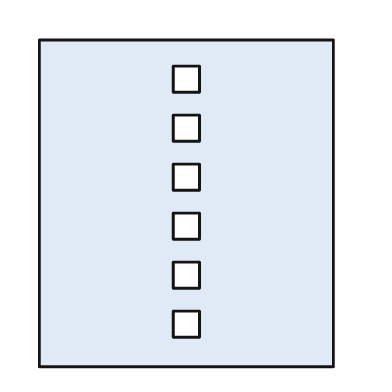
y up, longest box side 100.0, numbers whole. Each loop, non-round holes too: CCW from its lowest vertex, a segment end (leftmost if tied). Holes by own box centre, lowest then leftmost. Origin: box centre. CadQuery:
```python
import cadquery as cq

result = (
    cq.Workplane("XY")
    .moveTo(-45.0, -50.0)
    .lineTo(45.0, -50.0)
    .lineTo(45.0, 50.0)
    .lineTo(-45.0, 50.0)
    .close()
    .moveTo(-4.0, -41.0)
    .lineTo(4.0, -41.0)
    .lineTo(4.0, -33.0)
    .lineTo(-4.0, -33.0)
    .close()
    .moveTo(-4.0, -26.0)
    .lineTo(4.0, -26.0)
    .lineTo(4.0, -18.0)
    .lineTo(-4.0, -18.0)
    .close()
    .moveTo(-4.0, -11.0)
    .lineTo(4.0, -11.0)
    .lineTo(4.0, -3.0)
    .lineTo(-4.0, -3.0)
    .close()
    .moveTo(-4.0, 4.0)
    .lineTo(4.0, 4.0)
    .lineTo(4.0, 12.0)
    .lineTo(-4.0, 12.0)
    .close()
    .moveTo(-4.0, 19.0)
    .lineTo(4.0, 19.0)
    .lineTo(4.0, 27.0)
    .lineTo(-4.0, 27.0)
    .close()
    .moveTo(-4.0, 34.0)
    .lineTo(4.0, 34.0)
    .lineTo(4.0, 42.0)
    .lineTo(-4.0, 42.0)
    .close()
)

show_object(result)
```